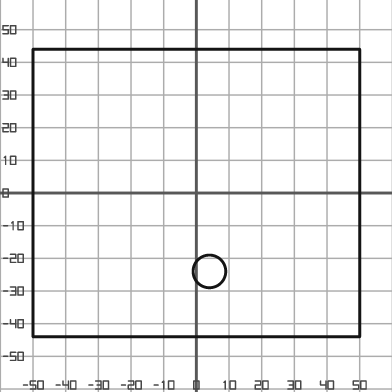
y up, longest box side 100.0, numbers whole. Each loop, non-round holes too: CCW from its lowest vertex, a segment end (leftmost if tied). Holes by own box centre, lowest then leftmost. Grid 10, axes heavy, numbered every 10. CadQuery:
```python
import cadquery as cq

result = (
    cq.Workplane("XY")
    .moveTo(-50.0, -44.0)
    .lineTo(50.0, -44.0)
    .lineTo(50.0, 44.0)
    .lineTo(-50.0, 44.0)
    .close()
    .moveTo(4.0, -24.0)
    .circle(5.0)
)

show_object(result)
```